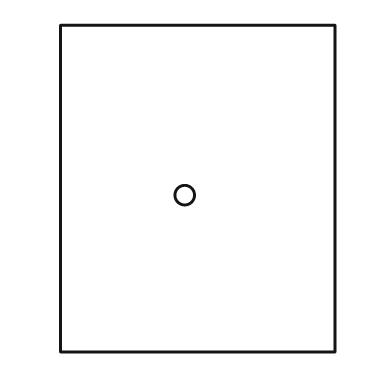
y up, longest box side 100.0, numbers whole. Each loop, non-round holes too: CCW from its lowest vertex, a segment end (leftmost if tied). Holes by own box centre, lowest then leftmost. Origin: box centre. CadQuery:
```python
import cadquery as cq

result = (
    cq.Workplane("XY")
    .moveTo(-42.0, -50.0)
    .lineTo(42.0, -50.0)
    .lineTo(42.0, 50.0)
    .lineTo(-42.0, 50.0)
    .close()
    .moveTo(-4.0, -2.0)
    .circle(3.0)
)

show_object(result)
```